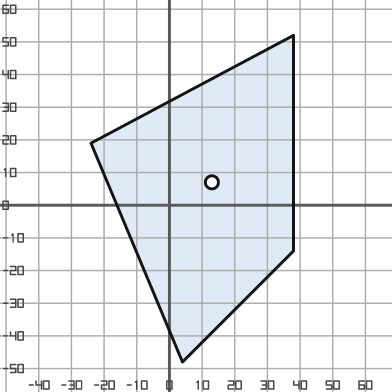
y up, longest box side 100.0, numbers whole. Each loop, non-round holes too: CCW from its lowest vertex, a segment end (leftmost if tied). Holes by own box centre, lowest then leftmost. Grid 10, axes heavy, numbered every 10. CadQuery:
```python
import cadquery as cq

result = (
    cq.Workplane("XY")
    .moveTo(4.0, -48.0)
    .lineTo(38.0, -14.0)
    .lineTo(38.0, 52.0)
    .lineTo(-24.0, 19.0)
    .close()
    .moveTo(13.0, 7.0)
    .circle(2.0)
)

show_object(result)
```